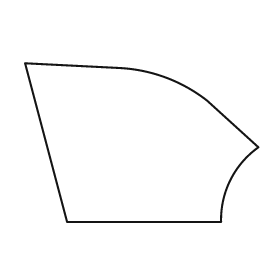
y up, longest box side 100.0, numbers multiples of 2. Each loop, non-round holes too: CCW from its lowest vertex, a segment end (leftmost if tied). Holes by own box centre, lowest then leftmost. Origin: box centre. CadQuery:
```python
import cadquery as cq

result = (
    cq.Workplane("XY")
    .moveTo(-32.0, -34.0)
    .lineTo(34.0, -34.0)
    .threePointArc((38.0, -16.0), (50.0, -2.0))
    .lineTo(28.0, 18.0)
    .threePointArc((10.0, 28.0), (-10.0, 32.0))
    .lineTo(-50.0, 34.0)
    .close()
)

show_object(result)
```